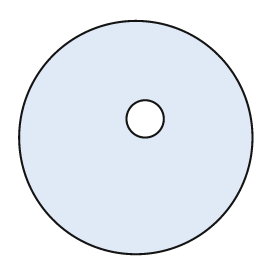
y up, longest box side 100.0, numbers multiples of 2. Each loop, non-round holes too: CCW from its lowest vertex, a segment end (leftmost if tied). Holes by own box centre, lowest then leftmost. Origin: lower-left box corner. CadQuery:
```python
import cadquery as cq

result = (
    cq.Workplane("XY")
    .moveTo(50.0, 50.0)
    .circle(50.0)
    .moveTo(54.0, 58.0)
    .circle(8.0)
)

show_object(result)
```